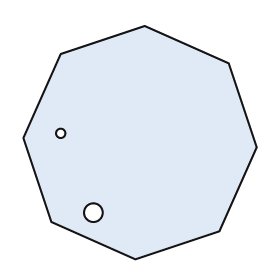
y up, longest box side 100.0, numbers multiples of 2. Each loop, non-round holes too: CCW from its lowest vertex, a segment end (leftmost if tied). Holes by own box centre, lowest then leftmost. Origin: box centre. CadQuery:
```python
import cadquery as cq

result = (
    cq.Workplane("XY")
    .moveTo(-2.0, -50.0)
    .lineTo(34.0, -38.0)
    .lineTo(50.0, -2.0)
    .lineTo(38.0, 34.0)
    .lineTo(2.0, 50.0)
    .lineTo(-34.0, 38.0)
    .lineTo(-50.0, 2.0)
    .lineTo(-38.0, -34.0)
    .close()
    .moveTo(-20.0, -30.0)
    .circle(4.0)
    .moveTo(-34.0, 4.0)
    .circle(2.0)
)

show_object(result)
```